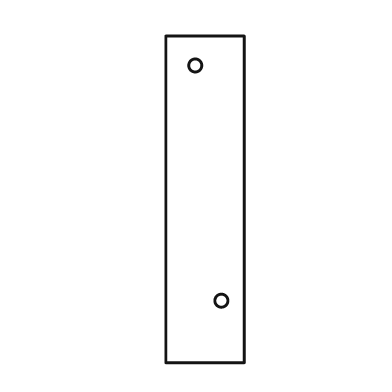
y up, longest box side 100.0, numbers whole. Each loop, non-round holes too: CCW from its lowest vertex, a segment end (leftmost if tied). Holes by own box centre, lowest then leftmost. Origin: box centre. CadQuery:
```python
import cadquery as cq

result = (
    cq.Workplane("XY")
    .moveTo(-12.0, -50.0)
    .lineTo(12.0, -50.0)
    .lineTo(12.0, 50.0)
    .lineTo(-12.0, 50.0)
    .close()
    .moveTo(5.0, -31.0)
    .circle(2.0)
    .moveTo(-3.0, 41.0)
    .circle(2.0)
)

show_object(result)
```